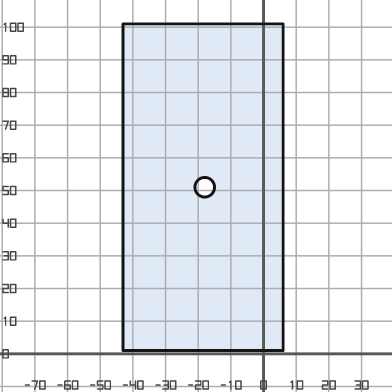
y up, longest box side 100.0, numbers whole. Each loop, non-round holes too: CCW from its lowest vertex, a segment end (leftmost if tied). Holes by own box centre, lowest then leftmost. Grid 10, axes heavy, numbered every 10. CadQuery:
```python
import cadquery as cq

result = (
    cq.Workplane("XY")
    .moveTo(-43.0, 1.0)
    .lineTo(6.0, 1.0)
    .lineTo(6.0, 101.0)
    .lineTo(-43.0, 101.0)
    .close()
    .moveTo(-18.0, 51.0)
    .circle(3.0)
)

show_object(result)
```